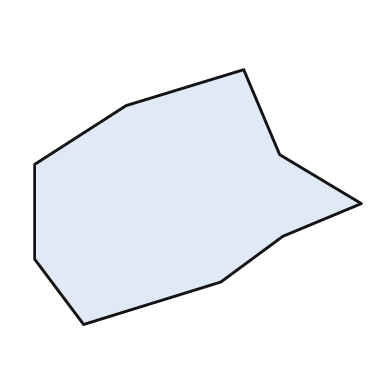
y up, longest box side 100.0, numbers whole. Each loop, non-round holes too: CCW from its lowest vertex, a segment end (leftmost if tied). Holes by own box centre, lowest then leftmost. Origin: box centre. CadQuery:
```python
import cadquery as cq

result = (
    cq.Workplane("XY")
    .moveTo(-35.0, -39.0)
    .lineTo(7.0, -26.0)
    .lineTo(26.0, -12.0)
    .lineTo(50.0, -2.0)
    .lineTo(25.0, 13.0)
    .lineTo(14.0, 39.0)
    .lineTo(-22.0, 28.0)
    .lineTo(-50.0, 10.0)
    .lineTo(-50.0, -19.0)
    .close()
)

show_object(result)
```